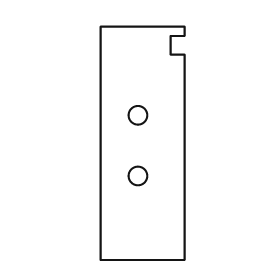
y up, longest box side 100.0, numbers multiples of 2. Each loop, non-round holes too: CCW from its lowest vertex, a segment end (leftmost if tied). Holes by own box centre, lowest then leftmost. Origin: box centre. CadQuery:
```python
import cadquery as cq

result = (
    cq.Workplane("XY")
    .moveTo(-18.0, -50.0)
    .lineTo(18.0, -50.0)
    .lineTo(18.0, 38.0)
    .lineTo(12.0, 38.0)
    .lineTo(12.0, 46.0)
    .lineTo(18.0, 46.0)
    .lineTo(18.0, 50.0)
    .lineTo(-18.0, 50.0)
    .close()
    .moveTo(-2.0, -14.0)
    .circle(4.0)
    .moveTo(-2.0, 12.0)
    .circle(4.0)
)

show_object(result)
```